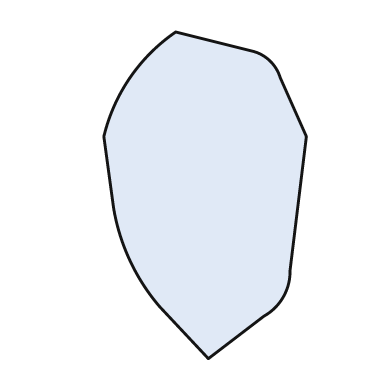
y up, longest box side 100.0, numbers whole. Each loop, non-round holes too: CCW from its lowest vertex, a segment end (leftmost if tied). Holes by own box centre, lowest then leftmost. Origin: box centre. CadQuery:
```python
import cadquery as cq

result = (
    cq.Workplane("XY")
    .moveTo(1.0, -50.0)
    .lineTo(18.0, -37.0)
    .threePointArc((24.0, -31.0), (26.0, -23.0))
    .lineTo(31.0, 18.0)
    .lineTo(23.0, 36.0)
    .threePointArc((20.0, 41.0), (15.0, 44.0))
    .lineTo(-9.0, 50.0)
    .threePointArc((-23.0, 36.0), (-31.0, 18.0))
    .lineTo(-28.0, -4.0)
    .threePointArc((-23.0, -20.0), (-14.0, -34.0))
    .close()
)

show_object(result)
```